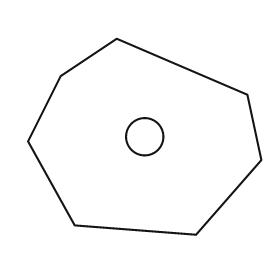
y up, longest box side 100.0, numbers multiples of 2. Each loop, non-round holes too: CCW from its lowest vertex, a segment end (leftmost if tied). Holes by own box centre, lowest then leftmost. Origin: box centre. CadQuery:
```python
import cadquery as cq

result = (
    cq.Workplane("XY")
    .moveTo(22.0, -42.0)
    .lineTo(50.0, -10.0)
    .lineTo(44.0, 18.0)
    .lineTo(-12.0, 42.0)
    .lineTo(-36.0, 26.0)
    .lineTo(-50.0, -2.0)
    .lineTo(-30.0, -38.0)
    .close()
    .moveTo(0.0, 0.0)
    .circle(8.0)
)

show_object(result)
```